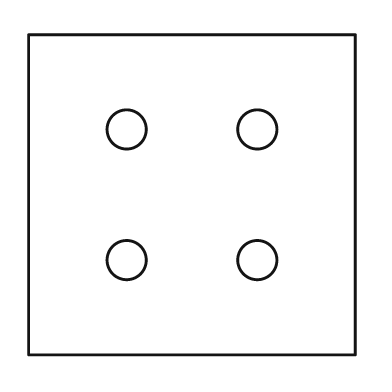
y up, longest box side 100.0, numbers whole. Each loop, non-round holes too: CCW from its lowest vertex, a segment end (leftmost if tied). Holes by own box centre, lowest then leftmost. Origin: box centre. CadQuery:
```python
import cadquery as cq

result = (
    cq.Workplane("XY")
    .moveTo(-50.0, -49.0)
    .lineTo(50.0, -49.0)
    .lineTo(50.0, 49.0)
    .lineTo(-50.0, 49.0)
    .close()
    .moveTo(-20.0, -20.0)
    .circle(6.0)
    .moveTo(20.0, -20.0)
    .circle(6.0)
    .moveTo(-20.0, 20.0)
    .circle(6.0)
    .moveTo(20.0, 20.0)
    .circle(6.0)
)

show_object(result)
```